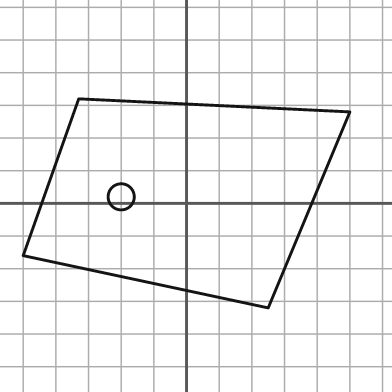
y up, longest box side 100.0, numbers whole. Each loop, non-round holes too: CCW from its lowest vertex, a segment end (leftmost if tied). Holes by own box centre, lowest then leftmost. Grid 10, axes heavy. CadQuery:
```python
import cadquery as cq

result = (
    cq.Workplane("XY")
    .moveTo(25.0, -32.0)
    .lineTo(50.0, 28.0)
    .lineTo(-33.0, 32.0)
    .lineTo(-50.0, -16.0)
    .close()
    .moveTo(-20.0, 2.0)
    .circle(4.0)
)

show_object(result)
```